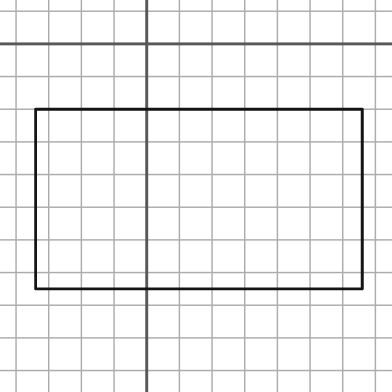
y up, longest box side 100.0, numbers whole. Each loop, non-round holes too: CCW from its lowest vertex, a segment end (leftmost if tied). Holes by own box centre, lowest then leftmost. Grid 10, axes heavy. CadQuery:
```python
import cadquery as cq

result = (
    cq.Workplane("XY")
    .moveTo(-34.0, -75.0)
    .lineTo(66.0, -75.0)
    .lineTo(66.0, -20.0)
    .lineTo(-34.0, -20.0)
    .close()
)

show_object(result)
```